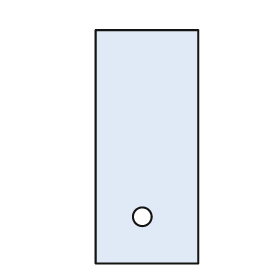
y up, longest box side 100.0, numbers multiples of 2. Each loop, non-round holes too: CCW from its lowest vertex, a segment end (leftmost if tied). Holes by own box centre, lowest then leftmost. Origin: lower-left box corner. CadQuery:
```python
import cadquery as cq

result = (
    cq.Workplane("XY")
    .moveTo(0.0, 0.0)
    .lineTo(44.0, 0.0)
    .lineTo(44.0, 100.0)
    .lineTo(0.0, 100.0)
    .close()
    .moveTo(20.0, 20.0)
    .circle(4.0)
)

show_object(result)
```